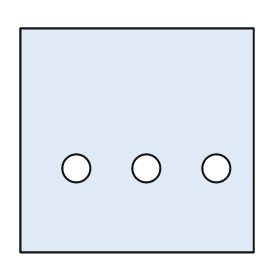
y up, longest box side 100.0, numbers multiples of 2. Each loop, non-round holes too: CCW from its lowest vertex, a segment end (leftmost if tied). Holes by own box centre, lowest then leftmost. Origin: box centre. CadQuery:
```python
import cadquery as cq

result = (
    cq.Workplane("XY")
    .moveTo(-50.0, -48.0)
    .lineTo(50.0, -48.0)
    .lineTo(50.0, 48.0)
    .lineTo(-50.0, 48.0)
    .close()
    .moveTo(-26.0, -12.0)
    .circle(6.0)
    .moveTo(4.0, -12.0)
    .circle(6.0)
    .moveTo(34.0, -12.0)
    .circle(6.0)
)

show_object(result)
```